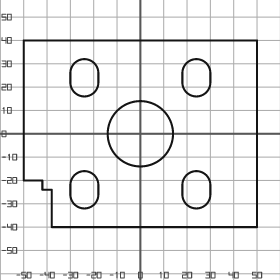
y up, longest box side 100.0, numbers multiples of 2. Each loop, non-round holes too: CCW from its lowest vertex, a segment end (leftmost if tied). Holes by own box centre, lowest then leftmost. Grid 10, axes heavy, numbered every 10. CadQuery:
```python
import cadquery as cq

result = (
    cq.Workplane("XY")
    .moveTo(-38.0, -40.0)
    .lineTo(50.0, -40.0)
    .lineTo(50.0, 40.0)
    .lineTo(-50.0, 40.0)
    .lineTo(-50.0, -20.0)
    .lineTo(-42.0, -20.0)
    .lineTo(-42.0, -24.0)
    .lineTo(-38.0, -24.0)
    .close()
    .moveTo(-30.0, -26.0)
    .threePointArc((-24.0, -32.0), (-18.0, -26.0))
    .lineTo(-18.0, -22.0)
    .threePointArc((-24.0, -16.0), (-30.0, -22.0))
    .close()
    .moveTo(18.0, -26.0)
    .threePointArc((24.0, -32.0), (30.0, -26.0))
    .lineTo(30.0, -22.0)
    .threePointArc((24.0, -16.0), (18.0, -22.0))
    .close()
    .moveTo(0.0, 0.0)
    .circle(14.0)
    .moveTo(-30.0, 22.0)
    .threePointArc((-24.0, 16.0), (-18.0, 22.0))
    .lineTo(-18.0, 26.0)
    .threePointArc((-24.0, 32.0), (-30.0, 26.0))
    .close()
    .moveTo(18.0, 22.0)
    .threePointArc((24.0, 16.0), (30.0, 22.0))
    .lineTo(30.0, 26.0)
    .threePointArc((24.0, 32.0), (18.0, 26.0))
    .close()
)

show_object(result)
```